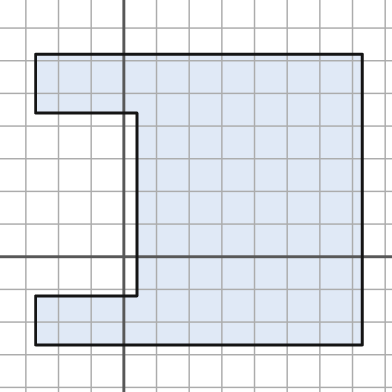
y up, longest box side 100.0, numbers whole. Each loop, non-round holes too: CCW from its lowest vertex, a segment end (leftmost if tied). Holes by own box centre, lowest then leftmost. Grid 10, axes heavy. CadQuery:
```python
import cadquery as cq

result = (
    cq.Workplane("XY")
    .moveTo(-27.0, -27.0)
    .lineTo(73.0, -27.0)
    .lineTo(73.0, 62.0)
    .lineTo(-27.0, 62.0)
    .lineTo(-27.0, 44.0)
    .lineTo(4.0, 44.0)
    .lineTo(4.0, -12.0)
    .lineTo(-27.0, -12.0)
    .close()
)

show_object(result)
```